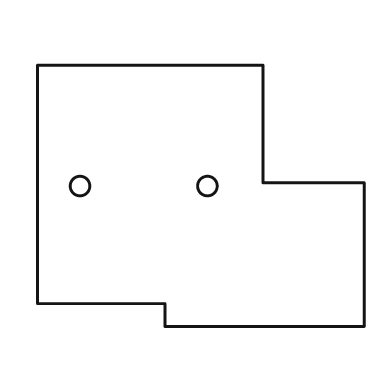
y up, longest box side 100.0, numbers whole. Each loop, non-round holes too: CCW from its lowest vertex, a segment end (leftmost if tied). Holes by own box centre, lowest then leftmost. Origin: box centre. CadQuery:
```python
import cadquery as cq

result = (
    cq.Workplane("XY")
    .moveTo(-11.0, -40.0)
    .lineTo(50.0, -40.0)
    .lineTo(50.0, 4.0)
    .lineTo(19.0, 4.0)
    .lineTo(19.0, 40.0)
    .lineTo(-50.0, 40.0)
    .lineTo(-50.0, -33.0)
    .lineTo(-11.0, -33.0)
    .close()
    .moveTo(-37.0, 3.0)
    .circle(3.0)
    .moveTo(2.0, 3.0)
    .circle(3.0)
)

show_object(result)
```